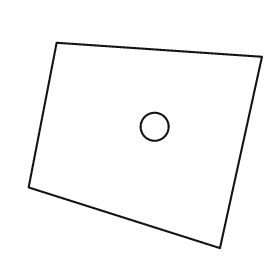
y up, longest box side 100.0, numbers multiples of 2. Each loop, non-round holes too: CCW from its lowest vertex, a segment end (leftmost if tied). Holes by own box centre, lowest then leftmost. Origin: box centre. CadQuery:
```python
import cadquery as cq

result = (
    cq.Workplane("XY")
    .moveTo(32.0, -44.0)
    .lineTo(50.0, 38.0)
    .lineTo(-38.0, 44.0)
    .lineTo(-50.0, -18.0)
    .close()
    .moveTo(4.0, 8.0)
    .circle(6.0)
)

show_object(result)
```